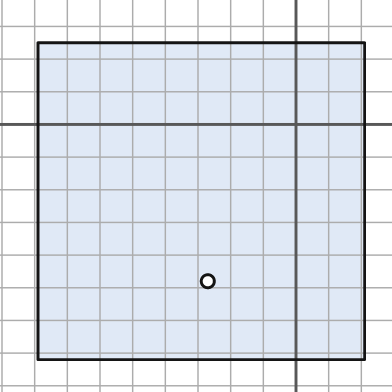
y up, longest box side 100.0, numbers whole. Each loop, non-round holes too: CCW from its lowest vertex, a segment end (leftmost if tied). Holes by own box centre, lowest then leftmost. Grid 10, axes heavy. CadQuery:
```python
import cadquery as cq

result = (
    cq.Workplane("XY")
    .moveTo(-79.0, -72.0)
    .lineTo(21.0, -72.0)
    .lineTo(21.0, 25.0)
    .lineTo(-79.0, 25.0)
    .close()
    .moveTo(-27.0, -48.0)
    .circle(2.0)
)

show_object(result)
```